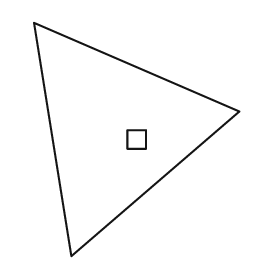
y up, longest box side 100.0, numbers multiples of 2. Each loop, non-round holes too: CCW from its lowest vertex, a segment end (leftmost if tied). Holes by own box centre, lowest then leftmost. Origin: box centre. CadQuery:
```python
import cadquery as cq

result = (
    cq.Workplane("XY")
    .moveTo(-28.0, -50.0)
    .lineTo(44.0, 12.0)
    .lineTo(-44.0, 50.0)
    .close()
    .moveTo(-4.0, -4.0)
    .lineTo(4.0, -4.0)
    .lineTo(4.0, 4.0)
    .lineTo(-4.0, 4.0)
    .close()
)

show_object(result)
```